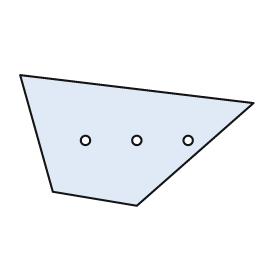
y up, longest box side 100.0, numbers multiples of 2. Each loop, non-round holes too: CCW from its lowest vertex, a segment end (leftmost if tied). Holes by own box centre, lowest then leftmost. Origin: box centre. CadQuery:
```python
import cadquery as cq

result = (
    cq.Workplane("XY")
    .moveTo(0.0, -28.0)
    .lineTo(50.0, 16.0)
    .lineTo(-50.0, 28.0)
    .lineTo(-36.0, -22.0)
    .close()
    .moveTo(-22.0, 0.0)
    .circle(2.0)
    .moveTo(0.0, 0.0)
    .circle(2.0)
    .moveTo(22.0, 0.0)
    .circle(2.0)
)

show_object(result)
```